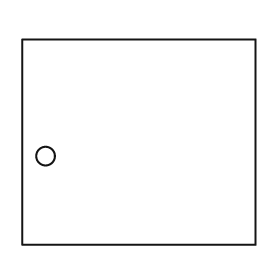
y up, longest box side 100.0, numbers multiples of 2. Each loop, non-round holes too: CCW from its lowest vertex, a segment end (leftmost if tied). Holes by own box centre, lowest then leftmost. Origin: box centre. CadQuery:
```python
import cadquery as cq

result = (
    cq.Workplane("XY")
    .moveTo(-50.0, -44.0)
    .lineTo(50.0, -44.0)
    .lineTo(50.0, 44.0)
    .lineTo(-50.0, 44.0)
    .close()
    .moveTo(-40.0, -6.0)
    .circle(4.0)
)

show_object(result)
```